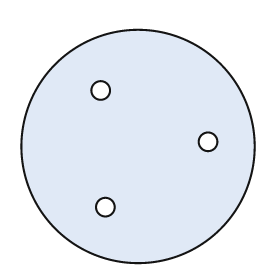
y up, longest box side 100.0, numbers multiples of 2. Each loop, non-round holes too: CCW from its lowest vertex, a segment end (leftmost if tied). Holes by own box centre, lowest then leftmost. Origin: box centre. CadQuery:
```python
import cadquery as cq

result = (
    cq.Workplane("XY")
    .moveTo(0.0, 0.0)
    .circle(50.0)
    .moveTo(-14.0, -26.0)
    .circle(4.0)
    .moveTo(30.0, 2.0)
    .circle(4.0)
    .moveTo(-16.0, 24.0)
    .circle(4.0)
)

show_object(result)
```